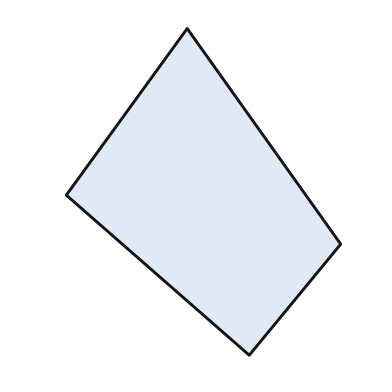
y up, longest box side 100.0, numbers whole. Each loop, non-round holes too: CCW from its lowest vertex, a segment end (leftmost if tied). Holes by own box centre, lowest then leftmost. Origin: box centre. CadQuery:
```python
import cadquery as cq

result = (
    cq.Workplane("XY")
    .moveTo(14.0, -50.0)
    .lineTo(42.0, -16.0)
    .lineTo(-5.0, 50.0)
    .lineTo(-42.0, -1.0)
    .close()
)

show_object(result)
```